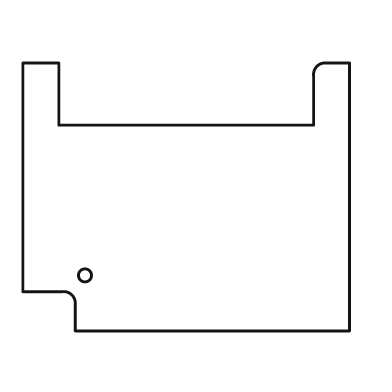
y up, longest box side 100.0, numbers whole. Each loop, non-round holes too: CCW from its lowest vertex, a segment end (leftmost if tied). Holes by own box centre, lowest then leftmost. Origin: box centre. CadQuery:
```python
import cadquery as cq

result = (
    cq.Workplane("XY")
    .moveTo(-34.0, -41.0)
    .lineTo(50.0, -41.0)
    .lineTo(50.0, 41.0)
    .lineTo(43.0, 41.0)
    .threePointArc((40.0, 40.0), (39.0, 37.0))
    .lineTo(39.0, 22.0)
    .lineTo(-39.0, 22.0)
    .lineTo(-39.0, 41.0)
    .lineTo(-50.0, 41.0)
    .lineTo(-50.0, -29.0)
    .lineTo(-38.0, -29.0)
    .threePointArc((-35.0, -30.0), (-34.0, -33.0))
    .close()
    .moveTo(-31.0, -24.0)
    .circle(2.0)
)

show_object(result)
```